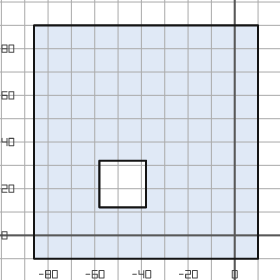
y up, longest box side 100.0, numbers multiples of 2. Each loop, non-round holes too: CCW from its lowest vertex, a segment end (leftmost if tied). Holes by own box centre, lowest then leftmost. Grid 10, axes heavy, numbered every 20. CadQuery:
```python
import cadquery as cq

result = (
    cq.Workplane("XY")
    .moveTo(-86.0, -10.0)
    .lineTo(10.0, -10.0)
    .lineTo(10.0, 90.0)
    .lineTo(-86.0, 90.0)
    .close()
    .moveTo(-58.0, 12.0)
    .lineTo(-38.0, 12.0)
    .lineTo(-38.0, 32.0)
    .lineTo(-58.0, 32.0)
    .close()
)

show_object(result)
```